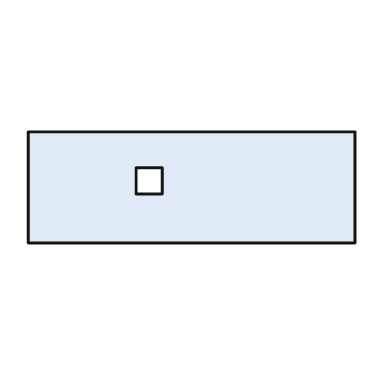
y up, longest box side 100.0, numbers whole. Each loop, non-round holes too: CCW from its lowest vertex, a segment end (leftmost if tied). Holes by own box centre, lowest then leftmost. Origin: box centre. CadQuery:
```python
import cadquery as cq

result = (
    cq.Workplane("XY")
    .moveTo(-50.0, -17.0)
    .lineTo(50.0, -17.0)
    .lineTo(50.0, 17.0)
    .lineTo(-50.0, 17.0)
    .close()
    .moveTo(-17.0, -2.0)
    .lineTo(-9.0, -2.0)
    .lineTo(-9.0, 6.0)
    .lineTo(-17.0, 6.0)
    .close()
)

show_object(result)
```